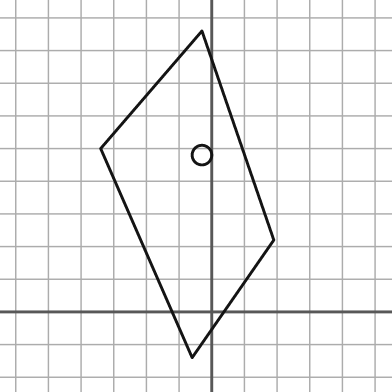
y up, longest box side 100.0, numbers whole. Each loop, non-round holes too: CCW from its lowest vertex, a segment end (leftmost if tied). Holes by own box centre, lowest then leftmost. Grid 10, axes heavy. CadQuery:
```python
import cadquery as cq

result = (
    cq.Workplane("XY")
    .moveTo(-6.0, -14.0)
    .lineTo(19.0, 22.0)
    .lineTo(-3.0, 86.0)
    .lineTo(-34.0, 50.0)
    .close()
    .moveTo(-3.0, 48.0)
    .circle(3.0)
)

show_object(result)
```